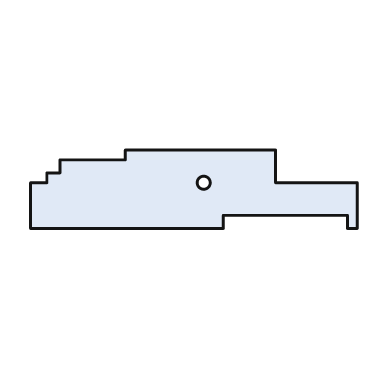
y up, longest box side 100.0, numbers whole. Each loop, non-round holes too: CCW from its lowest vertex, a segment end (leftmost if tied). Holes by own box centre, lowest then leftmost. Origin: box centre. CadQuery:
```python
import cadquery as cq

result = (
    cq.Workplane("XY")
    .moveTo(-50.0, -12.0)
    .lineTo(9.0, -12.0)
    .lineTo(9.0, -8.0)
    .lineTo(47.0, -8.0)
    .lineTo(47.0, -12.0)
    .lineTo(50.0, -12.0)
    .lineTo(50.0, 2.0)
    .lineTo(25.0, 2.0)
    .lineTo(25.0, 12.0)
    .lineTo(-21.0, 12.0)
    .lineTo(-21.0, 9.0)
    .lineTo(-41.0, 9.0)
    .lineTo(-41.0, 5.0)
    .lineTo(-45.0, 5.0)
    .lineTo(-45.0, 2.0)
    .lineTo(-50.0, 2.0)
    .close()
    .moveTo(3.0, 2.0)
    .circle(2.0)
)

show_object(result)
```